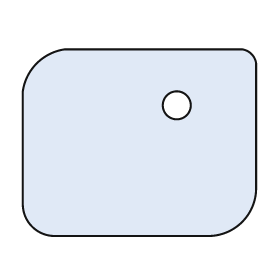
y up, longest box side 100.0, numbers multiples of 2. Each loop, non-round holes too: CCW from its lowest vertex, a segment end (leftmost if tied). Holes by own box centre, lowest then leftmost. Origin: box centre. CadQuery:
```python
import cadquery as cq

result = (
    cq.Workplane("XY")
    .moveTo(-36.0, -40.0)
    .lineTo(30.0, -40.0)
    .threePointArc((44.0, -34.0), (50.0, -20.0))
    .lineTo(50.0, 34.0)
    .threePointArc((48.0, 38.0), (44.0, 40.0))
    .lineTo(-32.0, 40.0)
    .threePointArc((-44.0, 34.0), (-50.0, 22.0))
    .lineTo(-50.0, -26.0)
    .threePointArc((-46.0, -36.0), (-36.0, -40.0))
    .close()
    .moveTo(16.0, 16.0)
    .circle(6.0)
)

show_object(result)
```